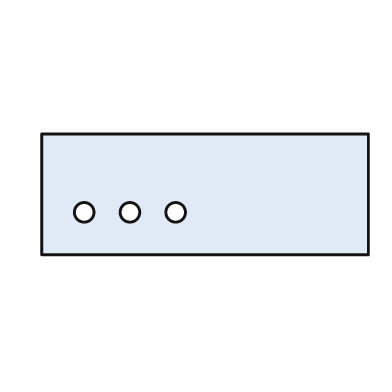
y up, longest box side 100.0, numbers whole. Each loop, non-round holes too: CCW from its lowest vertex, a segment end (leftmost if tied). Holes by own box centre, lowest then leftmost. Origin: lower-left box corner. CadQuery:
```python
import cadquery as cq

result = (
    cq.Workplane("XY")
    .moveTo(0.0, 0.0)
    .lineTo(100.0, 0.0)
    .lineTo(100.0, 37.0)
    .lineTo(0.0, 37.0)
    .close()
    .moveTo(13.0, 13.0)
    .circle(3.0)
    .moveTo(27.0, 13.0)
    .circle(3.0)
    .moveTo(41.0, 13.0)
    .circle(3.0)
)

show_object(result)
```